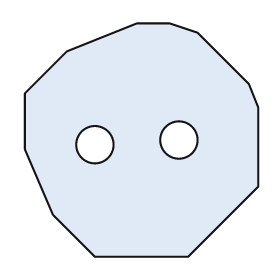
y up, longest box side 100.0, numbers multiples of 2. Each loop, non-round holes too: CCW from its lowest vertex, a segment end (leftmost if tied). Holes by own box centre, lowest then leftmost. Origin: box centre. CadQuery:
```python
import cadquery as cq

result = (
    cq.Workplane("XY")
    .moveTo(-20.0, -50.0)
    .lineTo(20.0, -50.0)
    .lineTo(50.0, -20.0)
    .lineTo(50.0, 14.0)
    .lineTo(46.0, 24.0)
    .lineTo(24.0, 46.0)
    .lineTo(12.0, 50.0)
    .lineTo(-2.0, 50.0)
    .lineTo(-32.0, 38.0)
    .lineTo(-50.0, 20.0)
    .lineTo(-50.0, -4.0)
    .lineTo(-38.0, -32.0)
    .close()
    .moveTo(-20.0, -2.0)
    .circle(8.0)
    .moveTo(16.0, 0.0)
    .circle(8.0)
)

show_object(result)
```